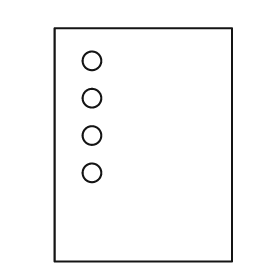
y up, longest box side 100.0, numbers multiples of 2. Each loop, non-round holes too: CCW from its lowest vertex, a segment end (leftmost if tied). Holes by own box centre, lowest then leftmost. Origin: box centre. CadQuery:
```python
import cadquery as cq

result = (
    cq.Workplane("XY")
    .moveTo(-38.0, -50.0)
    .lineTo(38.0, -50.0)
    .lineTo(38.0, 50.0)
    .lineTo(-38.0, 50.0)
    .close()
    .moveTo(-22.0, -12.0)
    .circle(4.0)
    .moveTo(-22.0, 4.0)
    .circle(4.0)
    .moveTo(-22.0, 20.0)
    .circle(4.0)
    .moveTo(-22.0, 36.0)
    .circle(4.0)
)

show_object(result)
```